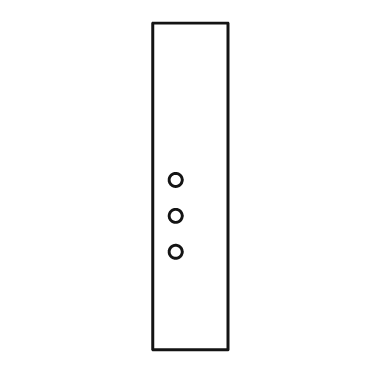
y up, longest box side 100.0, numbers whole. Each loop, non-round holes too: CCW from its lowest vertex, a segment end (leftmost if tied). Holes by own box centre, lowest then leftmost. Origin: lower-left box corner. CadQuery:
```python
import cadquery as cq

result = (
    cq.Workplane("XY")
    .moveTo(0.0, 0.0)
    .lineTo(23.0, 0.0)
    .lineTo(23.0, 100.0)
    .lineTo(0.0, 100.0)
    .close()
    .moveTo(7.0, 30.0)
    .circle(2.0)
    .moveTo(7.0, 41.0)
    .circle(2.0)
    .moveTo(7.0, 52.0)
    .circle(2.0)
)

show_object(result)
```